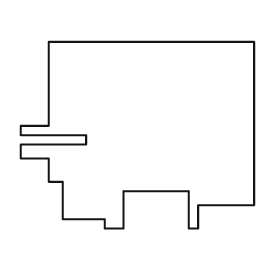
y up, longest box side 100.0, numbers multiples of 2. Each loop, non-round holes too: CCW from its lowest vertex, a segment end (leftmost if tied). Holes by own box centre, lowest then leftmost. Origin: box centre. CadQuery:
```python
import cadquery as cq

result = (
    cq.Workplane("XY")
    .moveTo(-14.0, -40.0)
    .lineTo(-6.0, -40.0)
    .lineTo(-6.0, -24.0)
    .lineTo(22.0, -24.0)
    .lineTo(22.0, -40.0)
    .lineTo(26.0, -40.0)
    .lineTo(26.0, -30.0)
    .lineTo(50.0, -30.0)
    .lineTo(50.0, 40.0)
    .lineTo(-38.0, 40.0)
    .lineTo(-38.0, 4.0)
    .lineTo(-50.0, 4.0)
    .lineTo(-50.0, 0.0)
    .lineTo(-22.0, 0.0)
    .lineTo(-22.0, -4.0)
    .lineTo(-50.0, -4.0)
    .lineTo(-50.0, -10.0)
    .lineTo(-38.0, -10.0)
    .lineTo(-38.0, -20.0)
    .lineTo(-32.0, -20.0)
    .lineTo(-32.0, -36.0)
    .lineTo(-14.0, -36.0)
    .close()
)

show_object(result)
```